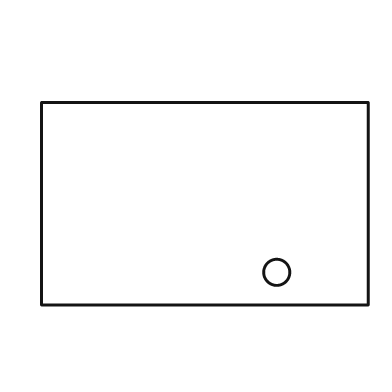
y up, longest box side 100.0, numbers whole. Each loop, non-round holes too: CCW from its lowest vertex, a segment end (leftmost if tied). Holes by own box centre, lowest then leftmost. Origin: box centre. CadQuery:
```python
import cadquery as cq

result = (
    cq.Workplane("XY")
    .moveTo(-50.0, -31.0)
    .lineTo(50.0, -31.0)
    .lineTo(50.0, 31.0)
    .lineTo(-50.0, 31.0)
    .close()
    .moveTo(22.0, -21.0)
    .circle(4.0)
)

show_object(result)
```